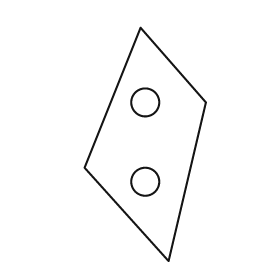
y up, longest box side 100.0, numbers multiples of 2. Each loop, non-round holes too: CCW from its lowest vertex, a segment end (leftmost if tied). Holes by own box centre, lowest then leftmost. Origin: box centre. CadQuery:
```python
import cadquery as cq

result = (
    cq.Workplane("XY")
    .moveTo(10.0, -50.0)
    .lineTo(26.0, 18.0)
    .lineTo(-2.0, 50.0)
    .lineTo(-26.0, -10.0)
    .close()
    .moveTo(0.0, -16.0)
    .circle(6.0)
    .moveTo(0.0, 18.0)
    .circle(6.0)
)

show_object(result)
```